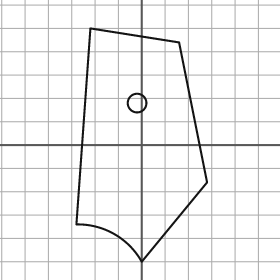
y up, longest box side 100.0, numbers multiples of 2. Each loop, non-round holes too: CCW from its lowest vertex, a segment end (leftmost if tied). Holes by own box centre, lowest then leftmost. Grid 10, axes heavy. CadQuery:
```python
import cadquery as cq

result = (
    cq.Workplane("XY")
    .moveTo(0.0, -50.0)
    .lineTo(28.0, -16.0)
    .lineTo(16.0, 44.0)
    .lineTo(-22.0, 50.0)
    .lineTo(-28.0, -34.0)
    .threePointArc((-12.0, -38.0), (0.0, -50.0))
    .close()
    .moveTo(-2.0, 18.0)
    .circle(4.0)
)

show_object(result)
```